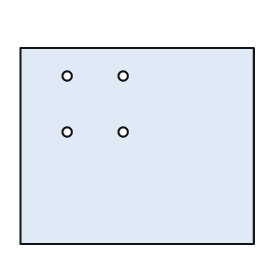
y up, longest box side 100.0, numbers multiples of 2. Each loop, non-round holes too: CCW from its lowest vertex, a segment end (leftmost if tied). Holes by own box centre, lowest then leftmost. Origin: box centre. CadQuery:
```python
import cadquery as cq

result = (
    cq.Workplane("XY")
    .moveTo(-50.0, -42.0)
    .lineTo(50.0, -42.0)
    .lineTo(50.0, 42.0)
    .lineTo(-50.0, 42.0)
    .close()
    .moveTo(-30.0, 6.0)
    .circle(2.0)
    .moveTo(-6.0, 6.0)
    .circle(2.0)
    .moveTo(-30.0, 30.0)
    .circle(2.0)
    .moveTo(-6.0, 30.0)
    .circle(2.0)
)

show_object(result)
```